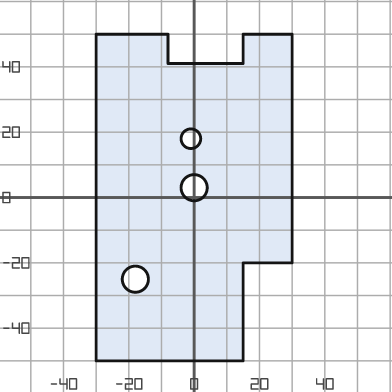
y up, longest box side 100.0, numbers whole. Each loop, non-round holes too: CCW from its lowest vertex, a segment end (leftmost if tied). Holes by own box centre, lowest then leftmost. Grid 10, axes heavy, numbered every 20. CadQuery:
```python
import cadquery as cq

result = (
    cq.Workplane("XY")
    .moveTo(-30.0, -50.0)
    .lineTo(15.0, -50.0)
    .lineTo(15.0, -20.0)
    .lineTo(30.0, -20.0)
    .lineTo(30.0, 50.0)
    .lineTo(15.0, 50.0)
    .lineTo(15.0, 41.0)
    .lineTo(-8.0, 41.0)
    .lineTo(-8.0, 50.0)
    .lineTo(-30.0, 50.0)
    .close()
    .moveTo(-18.0, -25.0)
    .circle(4.0)
    .moveTo(0.0, 3.0)
    .circle(4.0)
    .moveTo(-1.0, 18.0)
    .circle(3.0)
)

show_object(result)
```